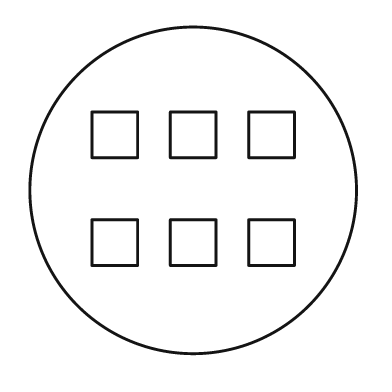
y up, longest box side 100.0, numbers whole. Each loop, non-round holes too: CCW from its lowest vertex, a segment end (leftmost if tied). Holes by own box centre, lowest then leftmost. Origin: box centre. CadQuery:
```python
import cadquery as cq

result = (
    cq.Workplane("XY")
    .moveTo(0.0, 0.0)
    .circle(50.0)
    .moveTo(-31.0, -23.0)
    .lineTo(-17.0, -23.0)
    .lineTo(-17.0, -9.0)
    .lineTo(-31.0, -9.0)
    .close()
    .moveTo(-7.0, -23.0)
    .lineTo(7.0, -23.0)
    .lineTo(7.0, -9.0)
    .lineTo(-7.0, -9.0)
    .close()
    .moveTo(17.0, -23.0)
    .lineTo(31.0, -23.0)
    .lineTo(31.0, -9.0)
    .lineTo(17.0, -9.0)
    .close()
    .moveTo(-31.0, 10.0)
    .lineTo(-17.0, 10.0)
    .lineTo(-17.0, 24.0)
    .lineTo(-31.0, 24.0)
    .close()
    .moveTo(-7.0, 10.0)
    .lineTo(7.0, 10.0)
    .lineTo(7.0, 24.0)
    .lineTo(-7.0, 24.0)
    .close()
    .moveTo(17.0, 10.0)
    .lineTo(31.0, 10.0)
    .lineTo(31.0, 24.0)
    .lineTo(17.0, 24.0)
    .close()
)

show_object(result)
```